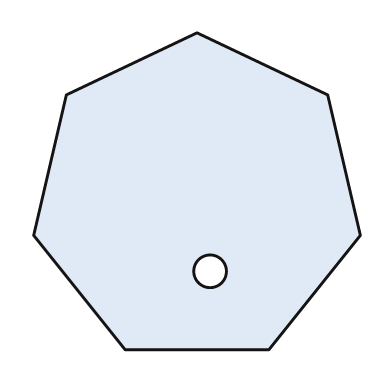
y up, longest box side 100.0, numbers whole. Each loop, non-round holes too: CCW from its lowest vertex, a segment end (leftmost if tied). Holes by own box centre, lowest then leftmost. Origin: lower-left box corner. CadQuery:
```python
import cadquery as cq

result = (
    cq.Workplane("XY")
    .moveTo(28.0, 0.0)
    .lineTo(72.0, 0.0)
    .lineTo(100.0, 35.0)
    .lineTo(90.0, 78.0)
    .lineTo(50.0, 97.0)
    .lineTo(10.0, 78.0)
    .lineTo(0.0, 35.0)
    .close()
    .moveTo(54.0, 24.0)
    .circle(5.0)
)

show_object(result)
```